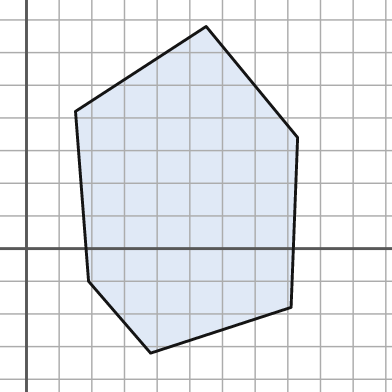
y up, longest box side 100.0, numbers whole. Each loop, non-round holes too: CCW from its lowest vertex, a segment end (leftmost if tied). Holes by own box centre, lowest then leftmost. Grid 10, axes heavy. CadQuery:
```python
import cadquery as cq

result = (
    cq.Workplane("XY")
    .moveTo(38.0, -32.0)
    .lineTo(81.0, -18.0)
    .lineTo(83.0, 34.0)
    .lineTo(55.0, 68.0)
    .lineTo(15.0, 42.0)
    .lineTo(19.0, -10.0)
    .close()
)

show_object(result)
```